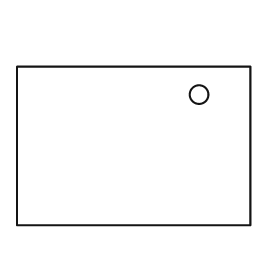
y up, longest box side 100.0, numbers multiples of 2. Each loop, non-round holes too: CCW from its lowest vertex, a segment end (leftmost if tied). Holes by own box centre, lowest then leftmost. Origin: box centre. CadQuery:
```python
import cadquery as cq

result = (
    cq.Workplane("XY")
    .moveTo(-50.0, -34.0)
    .lineTo(50.0, -34.0)
    .lineTo(50.0, 34.0)
    .lineTo(-50.0, 34.0)
    .close()
    .moveTo(28.0, 22.0)
    .circle(4.0)
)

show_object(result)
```